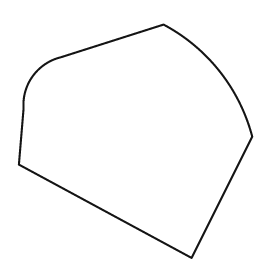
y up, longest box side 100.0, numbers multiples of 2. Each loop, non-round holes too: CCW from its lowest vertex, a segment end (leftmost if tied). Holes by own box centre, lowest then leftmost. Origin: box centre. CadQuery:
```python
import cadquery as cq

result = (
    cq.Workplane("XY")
    .moveTo(24.0, -50.0)
    .lineTo(50.0, 2.0)
    .threePointArc((36.0, 30.0), (12.0, 50.0))
    .lineTo(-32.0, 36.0)
    .threePointArc((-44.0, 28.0), (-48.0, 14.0))
    .lineTo(-50.0, -10.0)
    .close()
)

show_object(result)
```